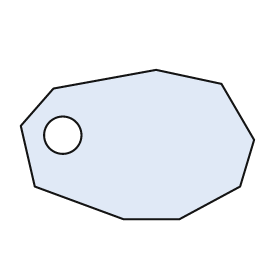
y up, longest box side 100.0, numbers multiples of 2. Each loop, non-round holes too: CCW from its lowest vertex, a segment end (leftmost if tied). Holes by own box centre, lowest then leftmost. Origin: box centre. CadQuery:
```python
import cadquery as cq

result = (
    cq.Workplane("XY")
    .moveTo(-6.0, -32.0)
    .lineTo(18.0, -32.0)
    .lineTo(44.0, -18.0)
    .lineTo(50.0, 2.0)
    .lineTo(36.0, 26.0)
    .lineTo(8.0, 32.0)
    .lineTo(-36.0, 24.0)
    .lineTo(-50.0, 8.0)
    .lineTo(-44.0, -18.0)
    .close()
    .moveTo(-32.0, 4.0)
    .circle(8.0)
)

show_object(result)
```